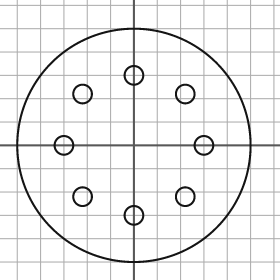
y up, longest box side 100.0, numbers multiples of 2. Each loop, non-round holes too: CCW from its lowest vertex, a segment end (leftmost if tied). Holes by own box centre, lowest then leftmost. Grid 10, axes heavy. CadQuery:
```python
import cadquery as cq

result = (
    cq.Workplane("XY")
    .moveTo(0.0, 0.0)
    .circle(50.0)
    .moveTo(0.0, -30.0)
    .circle(4.0)
    .moveTo(-22.0, -22.0)
    .circle(4.0)
    .moveTo(22.0, -22.0)
    .circle(4.0)
    .moveTo(-30.0, 0.0)
    .circle(4.0)
    .moveTo(30.0, 0.0)
    .circle(4.0)
    .moveTo(-22.0, 22.0)
    .circle(4.0)
    .moveTo(22.0, 22.0)
    .circle(4.0)
    .moveTo(0.0, 30.0)
    .circle(4.0)
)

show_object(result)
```